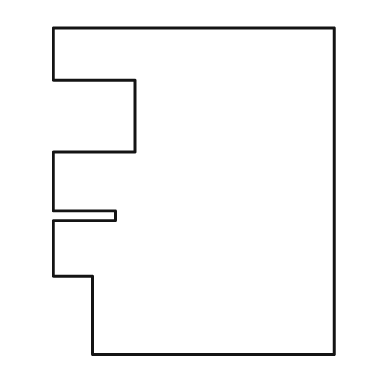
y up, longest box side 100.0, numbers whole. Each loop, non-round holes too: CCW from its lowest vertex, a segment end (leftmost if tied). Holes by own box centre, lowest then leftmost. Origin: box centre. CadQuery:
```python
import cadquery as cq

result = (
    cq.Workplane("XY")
    .moveTo(-31.0, -50.0)
    .lineTo(43.0, -50.0)
    .lineTo(43.0, 50.0)
    .lineTo(-43.0, 50.0)
    .lineTo(-43.0, 34.0)
    .lineTo(-18.0, 34.0)
    .lineTo(-18.0, 12.0)
    .lineTo(-43.0, 12.0)
    .lineTo(-43.0, -6.0)
    .lineTo(-24.0, -6.0)
    .lineTo(-24.0, -9.0)
    .lineTo(-43.0, -9.0)
    .lineTo(-43.0, -26.0)
    .lineTo(-31.0, -26.0)
    .close()
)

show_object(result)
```